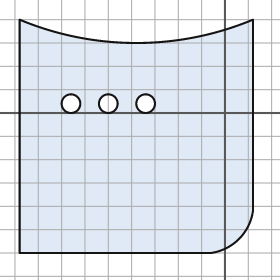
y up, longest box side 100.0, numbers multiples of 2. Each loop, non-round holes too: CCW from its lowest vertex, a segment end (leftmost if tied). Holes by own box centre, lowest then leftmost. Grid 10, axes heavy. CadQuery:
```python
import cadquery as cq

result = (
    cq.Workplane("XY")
    .moveTo(-88.0, -60.0)
    .lineTo(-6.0, -60.0)
    .threePointArc((6.0, -54.0), (12.0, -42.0))
    .lineTo(12.0, 40.0)
    .threePointArc((-38.0, 30.0), (-88.0, 40.0))
    .close()
    .moveTo(-66.0, 4.0)
    .circle(4.0)
    .moveTo(-50.0, 4.0)
    .circle(4.0)
    .moveTo(-34.0, 4.0)
    .circle(4.0)
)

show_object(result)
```